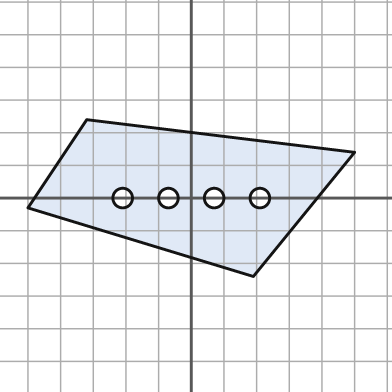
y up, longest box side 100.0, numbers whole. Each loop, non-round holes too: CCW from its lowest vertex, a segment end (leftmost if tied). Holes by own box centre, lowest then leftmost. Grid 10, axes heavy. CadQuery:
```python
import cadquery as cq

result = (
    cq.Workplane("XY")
    .moveTo(19.0, -24.0)
    .lineTo(50.0, 14.0)
    .lineTo(-32.0, 24.0)
    .lineTo(-50.0, -3.0)
    .close()
    .moveTo(-21.0, 0.0)
    .circle(3.0)
    .moveTo(-7.0, 0.0)
    .circle(3.0)
    .moveTo(7.0, 0.0)
    .circle(3.0)
    .moveTo(21.0, 0.0)
    .circle(3.0)
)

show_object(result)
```